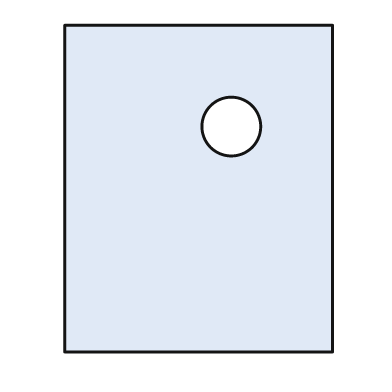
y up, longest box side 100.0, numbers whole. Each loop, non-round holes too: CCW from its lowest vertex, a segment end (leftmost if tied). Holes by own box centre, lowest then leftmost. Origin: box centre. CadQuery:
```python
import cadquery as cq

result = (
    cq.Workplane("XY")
    .moveTo(-41.0, -50.0)
    .lineTo(41.0, -50.0)
    .lineTo(41.0, 50.0)
    .lineTo(-41.0, 50.0)
    .close()
    .moveTo(10.0, 19.0)
    .circle(9.0)
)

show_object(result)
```